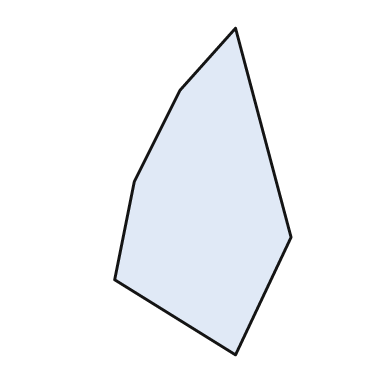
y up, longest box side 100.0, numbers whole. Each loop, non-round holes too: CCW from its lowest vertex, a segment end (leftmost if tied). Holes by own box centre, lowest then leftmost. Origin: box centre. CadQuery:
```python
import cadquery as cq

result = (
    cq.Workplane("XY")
    .moveTo(10.0, -50.0)
    .lineTo(27.0, -14.0)
    .lineTo(10.0, 50.0)
    .lineTo(-7.0, 31.0)
    .lineTo(-21.0, 3.0)
    .lineTo(-27.0, -27.0)
    .close()
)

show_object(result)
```